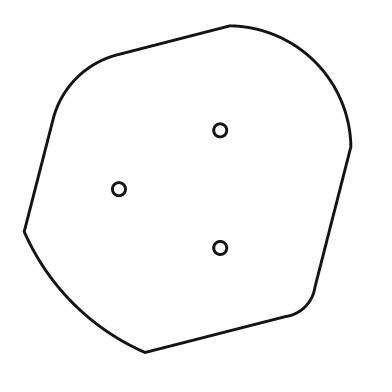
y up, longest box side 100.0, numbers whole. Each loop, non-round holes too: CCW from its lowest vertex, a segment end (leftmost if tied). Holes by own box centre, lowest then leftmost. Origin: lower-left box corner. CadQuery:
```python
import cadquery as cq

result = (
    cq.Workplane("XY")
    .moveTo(37.0, 0.0)
    .lineTo(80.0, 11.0)
    .threePointArc((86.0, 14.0), (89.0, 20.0))
    .lineTo(100.0, 63.0)
    .threePointArc((89.0, 89.0), (63.0, 100.0))
    .lineTo(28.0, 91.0)
    .threePointArc((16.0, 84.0), (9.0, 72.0))
    .lineTo(0.0, 37.0)
    .threePointArc((15.0, 15.0), (37.0, 0.0))
    .close()
    .moveTo(60.0, 32.0)
    .circle(2.0)
    .moveTo(29.0, 50.0)
    .circle(2.0)
    .moveTo(60.0, 68.0)
    .circle(2.0)
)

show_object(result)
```